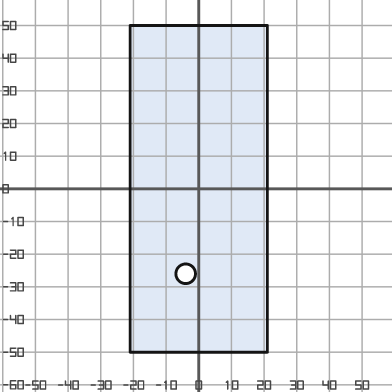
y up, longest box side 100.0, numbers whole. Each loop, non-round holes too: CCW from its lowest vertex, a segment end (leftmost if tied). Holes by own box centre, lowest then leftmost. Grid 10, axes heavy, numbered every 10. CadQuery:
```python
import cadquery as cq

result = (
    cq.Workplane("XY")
    .moveTo(-21.0, -50.0)
    .lineTo(21.0, -50.0)
    .lineTo(21.0, 50.0)
    .lineTo(-21.0, 50.0)
    .close()
    .moveTo(-4.0, -26.0)
    .circle(3.0)
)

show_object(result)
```